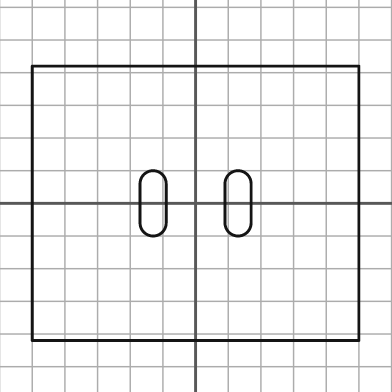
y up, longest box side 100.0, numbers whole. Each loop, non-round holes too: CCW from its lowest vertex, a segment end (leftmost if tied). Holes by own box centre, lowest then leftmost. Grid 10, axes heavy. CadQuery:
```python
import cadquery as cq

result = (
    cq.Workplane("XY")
    .moveTo(-50.0, -42.0)
    .lineTo(50.0, -42.0)
    .lineTo(50.0, 42.0)
    .lineTo(-50.0, 42.0)
    .close()
    .moveTo(-17.0, -6.0)
    .threePointArc((-13.0, -10.0), (-9.0, -6.0))
    .lineTo(-9.0, 6.0)
    .threePointArc((-13.0, 10.0), (-17.0, 6.0))
    .close()
    .moveTo(9.0, -6.0)
    .threePointArc((13.0, -10.0), (17.0, -6.0))
    .lineTo(17.0, 6.0)
    .threePointArc((13.0, 10.0), (9.0, 6.0))
    .close()
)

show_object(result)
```